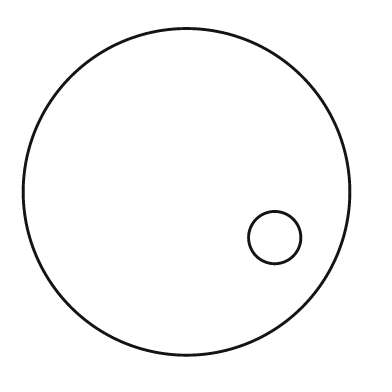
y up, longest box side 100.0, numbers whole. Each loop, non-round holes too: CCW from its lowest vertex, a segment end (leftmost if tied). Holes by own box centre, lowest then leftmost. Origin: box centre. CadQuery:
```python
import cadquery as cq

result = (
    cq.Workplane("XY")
    .moveTo(0.0, 0.0)
    .circle(50.0)
    .moveTo(27.0, -14.0)
    .circle(8.0)
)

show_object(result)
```